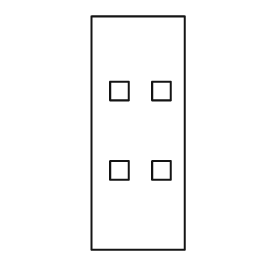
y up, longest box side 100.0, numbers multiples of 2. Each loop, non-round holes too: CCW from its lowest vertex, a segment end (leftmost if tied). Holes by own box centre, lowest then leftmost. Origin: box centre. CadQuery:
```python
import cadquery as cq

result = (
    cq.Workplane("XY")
    .moveTo(-20.0, -50.0)
    .lineTo(20.0, -50.0)
    .lineTo(20.0, 50.0)
    .lineTo(-20.0, 50.0)
    .close()
    .moveTo(-12.0, -20.0)
    .lineTo(-4.0, -20.0)
    .lineTo(-4.0, -12.0)
    .lineTo(-12.0, -12.0)
    .close()
    .moveTo(6.0, -20.0)
    .lineTo(14.0, -20.0)
    .lineTo(14.0, -12.0)
    .lineTo(6.0, -12.0)
    .close()
    .moveTo(-12.0, 14.0)
    .lineTo(-4.0, 14.0)
    .lineTo(-4.0, 22.0)
    .lineTo(-12.0, 22.0)
    .close()
    .moveTo(6.0, 14.0)
    .lineTo(14.0, 14.0)
    .lineTo(14.0, 22.0)
    .lineTo(6.0, 22.0)
    .close()
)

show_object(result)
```